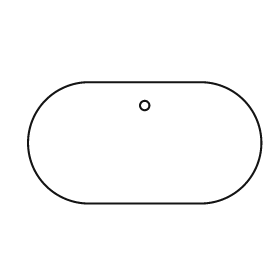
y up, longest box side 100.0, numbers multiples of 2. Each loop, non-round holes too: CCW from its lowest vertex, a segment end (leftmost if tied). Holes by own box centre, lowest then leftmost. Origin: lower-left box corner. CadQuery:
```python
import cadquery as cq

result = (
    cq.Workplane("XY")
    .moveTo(26.0, 0.0)
    .lineTo(74.0, 0.0)
    .threePointArc((100.0, 26.0), (74.0, 52.0))
    .lineTo(26.0, 52.0)
    .threePointArc((0.0, 26.0), (26.0, 0.0))
    .close()
    .moveTo(50.0, 42.0)
    .circle(2.0)
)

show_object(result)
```